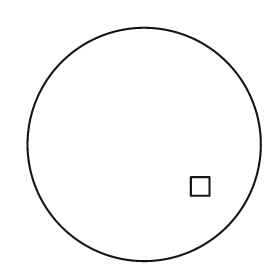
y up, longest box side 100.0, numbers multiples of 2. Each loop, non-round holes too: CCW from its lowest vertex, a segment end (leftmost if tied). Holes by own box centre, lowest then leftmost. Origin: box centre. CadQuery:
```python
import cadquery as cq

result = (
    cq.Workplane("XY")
    .moveTo(0.0, 0.0)
    .circle(50.0)
    .moveTo(20.0, -22.0)
    .lineTo(28.0, -22.0)
    .lineTo(28.0, -14.0)
    .lineTo(20.0, -14.0)
    .close()
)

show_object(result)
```